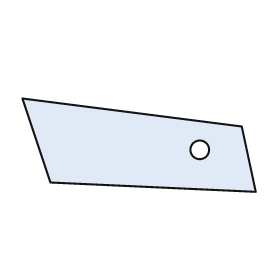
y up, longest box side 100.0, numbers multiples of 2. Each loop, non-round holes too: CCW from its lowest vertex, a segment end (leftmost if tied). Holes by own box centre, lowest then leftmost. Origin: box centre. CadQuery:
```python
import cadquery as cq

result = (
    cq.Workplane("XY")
    .moveTo(50.0, -20.0)
    .lineTo(44.0, 8.0)
    .lineTo(-50.0, 20.0)
    .lineTo(-38.0, -16.0)
    .close()
    .moveTo(26.0, -2.0)
    .circle(4.0)
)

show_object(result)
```